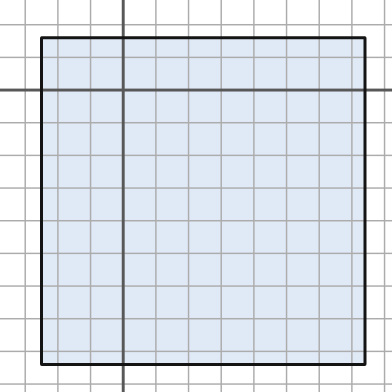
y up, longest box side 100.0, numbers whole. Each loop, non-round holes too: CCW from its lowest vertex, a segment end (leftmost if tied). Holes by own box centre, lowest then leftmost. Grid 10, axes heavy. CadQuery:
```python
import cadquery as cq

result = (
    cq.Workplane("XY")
    .moveTo(-25.0, -84.0)
    .lineTo(74.0, -84.0)
    .lineTo(74.0, 16.0)
    .lineTo(-25.0, 16.0)
    .close()
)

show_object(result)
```